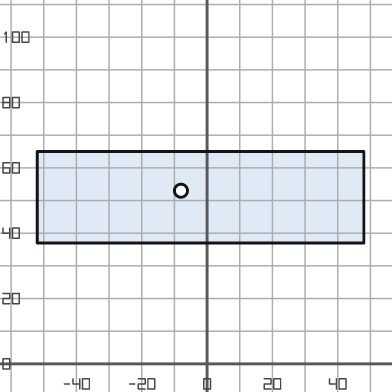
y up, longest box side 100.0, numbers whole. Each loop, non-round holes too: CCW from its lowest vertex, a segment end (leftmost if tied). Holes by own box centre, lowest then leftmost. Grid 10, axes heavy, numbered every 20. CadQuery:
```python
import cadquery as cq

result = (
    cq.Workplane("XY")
    .moveTo(-52.0, 37.0)
    .lineTo(48.0, 37.0)
    .lineTo(48.0, 65.0)
    .lineTo(-52.0, 65.0)
    .close()
    .moveTo(-8.0, 53.0)
    .circle(2.0)
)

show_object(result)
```